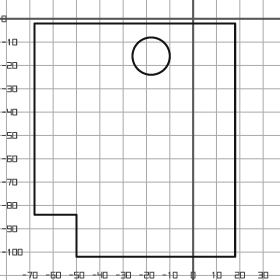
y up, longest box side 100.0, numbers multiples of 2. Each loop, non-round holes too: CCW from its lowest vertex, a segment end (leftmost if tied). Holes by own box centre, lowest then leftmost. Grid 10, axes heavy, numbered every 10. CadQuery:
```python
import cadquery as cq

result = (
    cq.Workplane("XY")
    .moveTo(-50.0, -102.0)
    .lineTo(18.0, -102.0)
    .lineTo(18.0, -2.0)
    .lineTo(-68.0, -2.0)
    .lineTo(-68.0, -84.0)
    .lineTo(-50.0, -84.0)
    .close()
    .moveTo(-18.0, -16.0)
    .circle(8.0)
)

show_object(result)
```